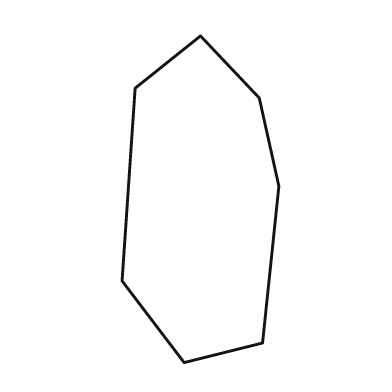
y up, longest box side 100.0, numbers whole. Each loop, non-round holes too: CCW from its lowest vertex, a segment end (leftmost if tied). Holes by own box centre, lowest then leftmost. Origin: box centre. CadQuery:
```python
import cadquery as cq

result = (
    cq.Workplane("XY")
    .moveTo(-5.0, -50.0)
    .lineTo(19.0, -44.0)
    .lineTo(24.0, 4.0)
    .lineTo(18.0, 31.0)
    .lineTo(0.0, 50.0)
    .lineTo(-20.0, 34.0)
    .lineTo(-24.0, -25.0)
    .close()
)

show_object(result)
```